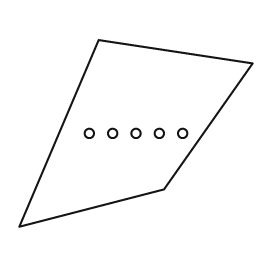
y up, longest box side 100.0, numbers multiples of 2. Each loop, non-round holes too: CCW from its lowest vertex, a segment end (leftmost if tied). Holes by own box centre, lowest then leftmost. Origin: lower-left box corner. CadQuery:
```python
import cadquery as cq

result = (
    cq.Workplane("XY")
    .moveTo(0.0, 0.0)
    .lineTo(62.0, 16.0)
    .lineTo(100.0, 70.0)
    .lineTo(34.0, 80.0)
    .close()
    .moveTo(30.0, 40.0)
    .circle(2.0)
    .moveTo(40.0, 40.0)
    .circle(2.0)
    .moveTo(50.0, 40.0)
    .circle(2.0)
    .moveTo(60.0, 40.0)
    .circle(2.0)
    .moveTo(70.0, 40.0)
    .circle(2.0)
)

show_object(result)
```